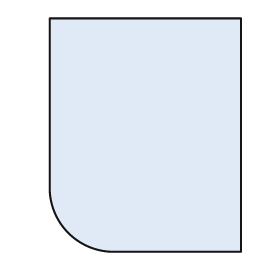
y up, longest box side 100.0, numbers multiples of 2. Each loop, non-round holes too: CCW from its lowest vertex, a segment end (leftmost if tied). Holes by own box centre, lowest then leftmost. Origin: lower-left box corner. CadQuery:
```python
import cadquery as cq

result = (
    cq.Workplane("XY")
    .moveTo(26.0, 0.0)
    .lineTo(82.0, 0.0)
    .lineTo(82.0, 100.0)
    .lineTo(0.0, 100.0)
    .lineTo(0.0, 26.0)
    .threePointArc((8.0, 8.0), (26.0, 0.0))
    .close()
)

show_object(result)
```